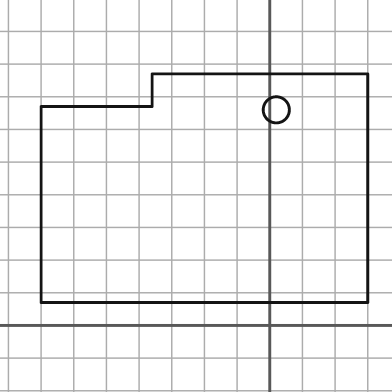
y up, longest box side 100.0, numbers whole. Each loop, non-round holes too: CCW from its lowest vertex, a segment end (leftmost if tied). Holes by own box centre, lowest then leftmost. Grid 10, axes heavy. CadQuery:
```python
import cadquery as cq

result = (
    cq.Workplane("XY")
    .moveTo(-70.0, 7.0)
    .lineTo(30.0, 7.0)
    .lineTo(30.0, 77.0)
    .lineTo(-36.0, 77.0)
    .lineTo(-36.0, 67.0)
    .lineTo(-70.0, 67.0)
    .close()
    .moveTo(2.0, 66.0)
    .circle(4.0)
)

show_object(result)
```